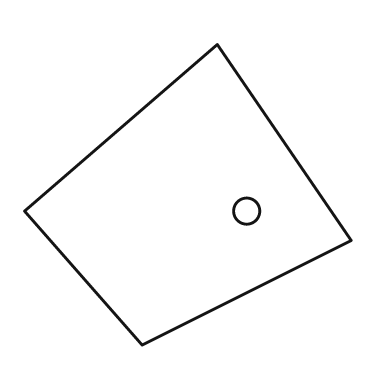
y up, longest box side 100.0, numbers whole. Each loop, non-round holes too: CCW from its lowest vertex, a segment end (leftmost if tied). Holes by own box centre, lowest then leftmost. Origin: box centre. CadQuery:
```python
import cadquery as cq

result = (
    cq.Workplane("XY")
    .moveTo(-14.0, -46.0)
    .lineTo(50.0, -14.0)
    .lineTo(9.0, 46.0)
    .lineTo(-50.0, -5.0)
    .close()
    .moveTo(18.0, -5.0)
    .circle(4.0)
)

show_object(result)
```